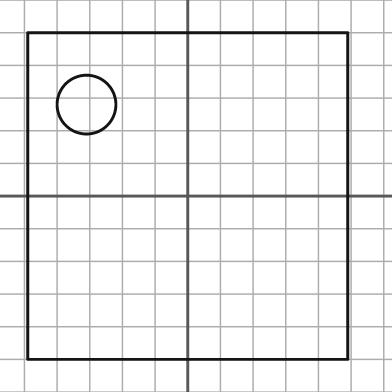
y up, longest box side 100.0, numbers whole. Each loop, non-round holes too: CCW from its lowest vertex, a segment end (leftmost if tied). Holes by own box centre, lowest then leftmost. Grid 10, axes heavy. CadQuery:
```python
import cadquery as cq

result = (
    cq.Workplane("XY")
    .moveTo(-49.0, -50.0)
    .lineTo(49.0, -50.0)
    .lineTo(49.0, 50.0)
    .lineTo(-49.0, 50.0)
    .close()
    .moveTo(-31.0, 28.0)
    .circle(9.0)
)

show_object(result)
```